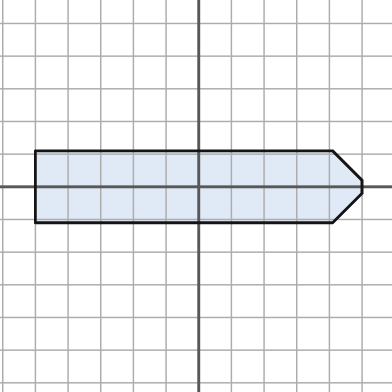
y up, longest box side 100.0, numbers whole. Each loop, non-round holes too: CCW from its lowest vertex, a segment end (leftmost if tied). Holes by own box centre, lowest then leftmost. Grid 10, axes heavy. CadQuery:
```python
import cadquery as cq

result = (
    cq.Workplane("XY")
    .moveTo(-50.0, -11.0)
    .lineTo(41.0, -11.0)
    .lineTo(50.0, -2.0)
    .lineTo(50.0, 2.0)
    .lineTo(41.0, 11.0)
    .lineTo(-50.0, 11.0)
    .close()
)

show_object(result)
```